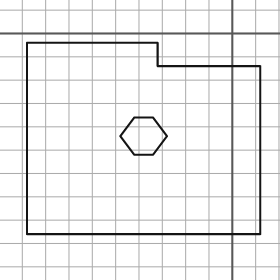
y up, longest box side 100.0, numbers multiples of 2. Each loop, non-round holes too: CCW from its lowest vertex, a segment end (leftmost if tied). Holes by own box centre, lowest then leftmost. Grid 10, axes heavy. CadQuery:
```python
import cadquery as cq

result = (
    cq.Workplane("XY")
    .moveTo(-88.0, -86.0)
    .lineTo(12.0, -86.0)
    .lineTo(12.0, -14.0)
    .lineTo(-32.0, -14.0)
    .lineTo(-32.0, -4.0)
    .lineTo(-88.0, -4.0)
    .close()
    .moveTo(-42.0, -52.0)
    .lineTo(-34.0, -52.0)
    .lineTo(-28.0, -44.0)
    .lineTo(-34.0, -36.0)
    .lineTo(-42.0, -36.0)
    .lineTo(-48.0, -44.0)
    .close()
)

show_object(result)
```